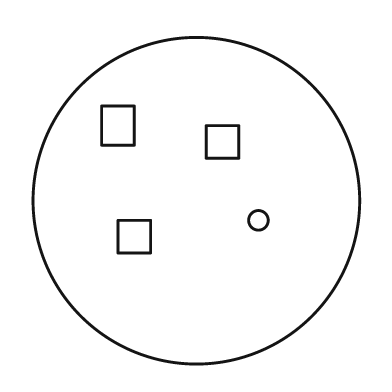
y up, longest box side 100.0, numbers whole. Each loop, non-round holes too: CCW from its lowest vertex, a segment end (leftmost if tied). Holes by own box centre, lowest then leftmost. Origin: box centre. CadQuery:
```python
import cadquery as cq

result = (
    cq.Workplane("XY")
    .moveTo(0.0, 0.0)
    .circle(50.0)
    .moveTo(-24.0, -16.0)
    .lineTo(-14.0, -16.0)
    .lineTo(-14.0, -6.0)
    .lineTo(-24.0, -6.0)
    .close()
    .moveTo(19.0, -6.0)
    .circle(3.0)
    .moveTo(3.0, 13.0)
    .lineTo(13.0, 13.0)
    .lineTo(13.0, 23.0)
    .lineTo(3.0, 23.0)
    .close()
    .moveTo(-29.0, 17.0)
    .lineTo(-19.0, 17.0)
    .lineTo(-19.0, 29.0)
    .lineTo(-29.0, 29.0)
    .close()
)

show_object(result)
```